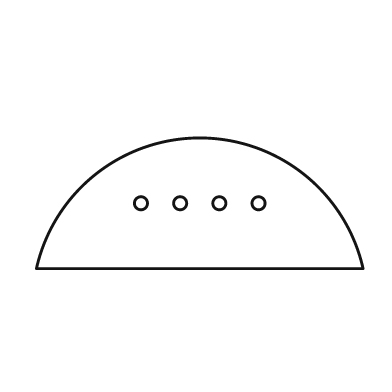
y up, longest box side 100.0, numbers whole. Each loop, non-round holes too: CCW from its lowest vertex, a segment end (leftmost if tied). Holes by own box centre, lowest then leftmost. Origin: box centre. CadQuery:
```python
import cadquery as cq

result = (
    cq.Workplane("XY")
    .moveTo(-50.0, -20.0)
    .lineTo(50.0, -20.0)
    .threePointArc((0.0, 20.0), (-50.0, -20.0))
    .close()
    .moveTo(-18.0, 0.0)
    .circle(2.0)
    .moveTo(-6.0, 0.0)
    .circle(2.0)
    .moveTo(6.0, 0.0)
    .circle(2.0)
    .moveTo(18.0, 0.0)
    .circle(2.0)
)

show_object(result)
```